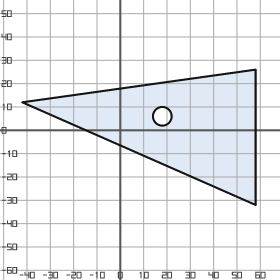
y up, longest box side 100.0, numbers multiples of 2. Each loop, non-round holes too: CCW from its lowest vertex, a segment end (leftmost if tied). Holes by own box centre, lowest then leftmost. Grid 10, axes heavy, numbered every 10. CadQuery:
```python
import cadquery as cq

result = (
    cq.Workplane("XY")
    .moveTo(58.0, -32.0)
    .lineTo(58.0, 26.0)
    .lineTo(-42.0, 12.0)
    .close()
    .moveTo(18.0, 6.0)
    .circle(4.0)
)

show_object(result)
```